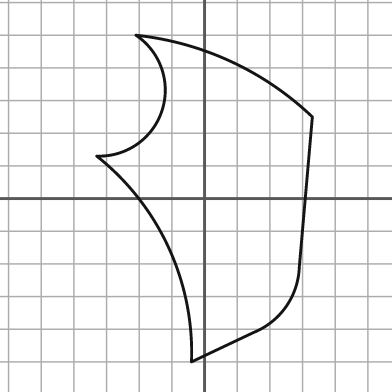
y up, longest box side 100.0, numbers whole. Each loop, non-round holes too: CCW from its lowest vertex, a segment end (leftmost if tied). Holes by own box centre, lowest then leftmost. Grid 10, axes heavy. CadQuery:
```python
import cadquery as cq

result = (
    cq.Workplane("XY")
    .moveTo(-4.0, -50.0)
    .lineTo(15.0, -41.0)
    .threePointArc((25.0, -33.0), (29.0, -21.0))
    .lineTo(33.0, 25.0)
    .threePointArc((8.0, 42.0), (-21.0, 50.0))
    .threePointArc((-13.0, 27.0), (-33.0, 13.0))
    .threePointArc((-11.0, -15.0), (-4.0, -50.0))
    .close()
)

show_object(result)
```